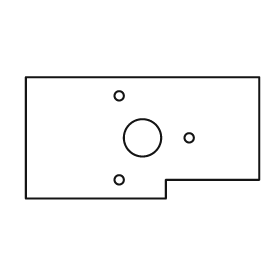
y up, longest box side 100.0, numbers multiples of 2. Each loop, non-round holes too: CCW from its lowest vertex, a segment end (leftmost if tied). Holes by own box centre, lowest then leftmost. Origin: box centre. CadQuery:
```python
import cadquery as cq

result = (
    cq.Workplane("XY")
    .moveTo(-50.0, -26.0)
    .lineTo(10.0, -26.0)
    .lineTo(10.0, -18.0)
    .lineTo(50.0, -18.0)
    .lineTo(50.0, 26.0)
    .lineTo(-50.0, 26.0)
    .close()
    .moveTo(-10.0, -18.0)
    .circle(2.0)
    .moveTo(0.0, 0.0)
    .circle(8.0)
    .moveTo(20.0, 0.0)
    .circle(2.0)
    .moveTo(-10.0, 18.0)
    .circle(2.0)
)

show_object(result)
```